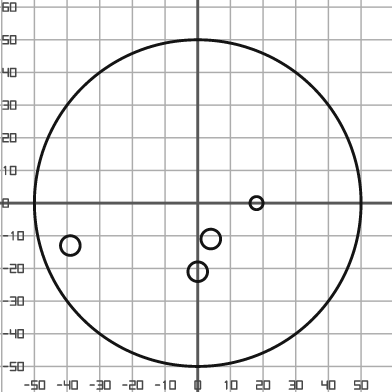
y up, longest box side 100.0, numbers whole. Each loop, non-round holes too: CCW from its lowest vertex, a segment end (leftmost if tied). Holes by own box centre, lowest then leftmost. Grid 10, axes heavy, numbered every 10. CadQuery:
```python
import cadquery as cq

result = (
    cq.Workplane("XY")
    .moveTo(0.0, 0.0)
    .circle(50.0)
    .moveTo(0.0, -21.0)
    .circle(3.0)
    .moveTo(-39.0, -13.0)
    .circle(3.0)
    .moveTo(4.0, -11.0)
    .circle(3.0)
    .moveTo(18.0, 0.0)
    .circle(2.0)
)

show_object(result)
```